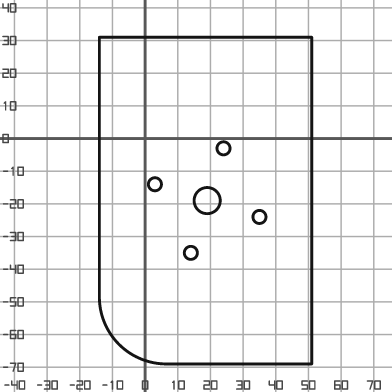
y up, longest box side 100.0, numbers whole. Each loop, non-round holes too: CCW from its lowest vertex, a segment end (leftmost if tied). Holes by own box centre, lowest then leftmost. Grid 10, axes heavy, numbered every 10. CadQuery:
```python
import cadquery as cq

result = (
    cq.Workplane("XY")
    .moveTo(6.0, -69.0)
    .lineTo(51.0, -69.0)
    .lineTo(51.0, 31.0)
    .lineTo(-14.0, 31.0)
    .lineTo(-14.0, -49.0)
    .threePointArc((-8.0, -63.0), (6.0, -69.0))
    .close()
    .moveTo(14.0, -35.0)
    .circle(2.0)
    .moveTo(35.0, -24.0)
    .circle(2.0)
    .moveTo(19.0, -19.0)
    .circle(4.0)
    .moveTo(3.0, -14.0)
    .circle(2.0)
    .moveTo(24.0, -3.0)
    .circle(2.0)
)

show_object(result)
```